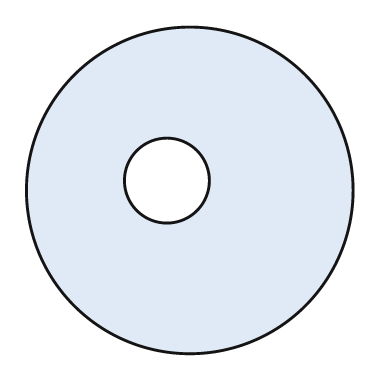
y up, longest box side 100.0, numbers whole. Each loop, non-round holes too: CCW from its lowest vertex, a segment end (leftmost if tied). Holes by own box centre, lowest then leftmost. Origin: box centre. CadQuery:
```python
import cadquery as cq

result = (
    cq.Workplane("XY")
    .moveTo(0.0, 0.0)
    .circle(50.0)
    .moveTo(-7.0, 3.0)
    .circle(13.0)
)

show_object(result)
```